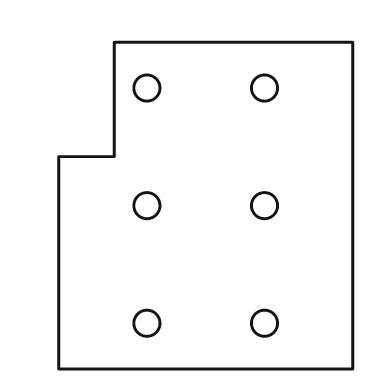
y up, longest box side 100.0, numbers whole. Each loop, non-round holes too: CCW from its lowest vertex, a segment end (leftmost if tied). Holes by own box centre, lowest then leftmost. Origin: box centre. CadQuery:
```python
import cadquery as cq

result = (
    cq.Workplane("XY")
    .moveTo(-45.0, -50.0)
    .lineTo(45.0, -50.0)
    .lineTo(45.0, 50.0)
    .lineTo(-28.0, 50.0)
    .lineTo(-28.0, 15.0)
    .lineTo(-45.0, 15.0)
    .close()
    .moveTo(-18.0, -36.0)
    .circle(4.0)
    .moveTo(18.0, -36.0)
    .circle(4.0)
    .moveTo(-18.0, 0.0)
    .circle(4.0)
    .moveTo(18.0, 0.0)
    .circle(4.0)
    .moveTo(-18.0, 36.0)
    .circle(4.0)
    .moveTo(18.0, 36.0)
    .circle(4.0)
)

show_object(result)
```